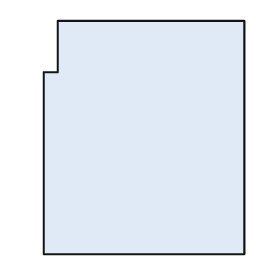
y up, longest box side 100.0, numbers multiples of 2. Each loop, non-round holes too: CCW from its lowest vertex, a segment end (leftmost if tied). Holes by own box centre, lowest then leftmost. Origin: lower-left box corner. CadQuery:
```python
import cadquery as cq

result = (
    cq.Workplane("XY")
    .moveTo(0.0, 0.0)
    .lineTo(86.0, 0.0)
    .lineTo(86.0, 100.0)
    .lineTo(6.0, 100.0)
    .lineTo(6.0, 78.0)
    .lineTo(0.0, 78.0)
    .close()
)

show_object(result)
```